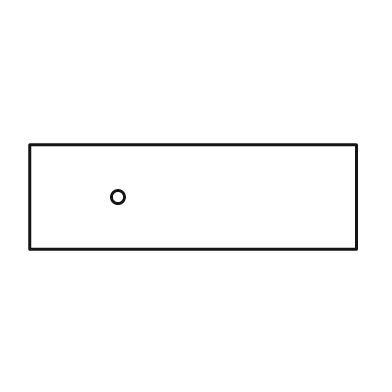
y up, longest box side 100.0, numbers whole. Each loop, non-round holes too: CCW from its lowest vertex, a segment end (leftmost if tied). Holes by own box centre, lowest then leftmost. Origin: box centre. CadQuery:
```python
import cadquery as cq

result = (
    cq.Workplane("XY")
    .moveTo(-50.0, -16.0)
    .lineTo(50.0, -16.0)
    .lineTo(50.0, 16.0)
    .lineTo(-50.0, 16.0)
    .close()
    .moveTo(-23.0, 0.0)
    .circle(2.0)
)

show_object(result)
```